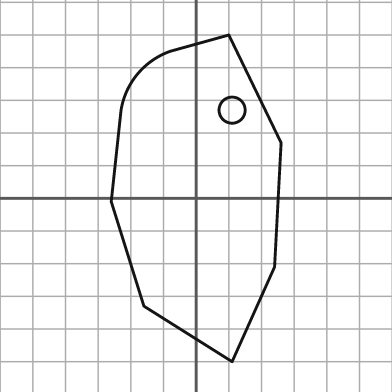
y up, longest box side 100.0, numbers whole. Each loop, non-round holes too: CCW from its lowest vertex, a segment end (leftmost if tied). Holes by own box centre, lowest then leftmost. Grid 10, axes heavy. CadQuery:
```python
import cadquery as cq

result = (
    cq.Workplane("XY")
    .moveTo(11.0, -50.0)
    .lineTo(24.0, -21.0)
    .lineTo(26.0, 17.0)
    .lineTo(10.0, 50.0)
    .lineTo(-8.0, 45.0)
    .threePointArc((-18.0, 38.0), (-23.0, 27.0))
    .lineTo(-26.0, -1.0)
    .lineTo(-16.0, -33.0)
    .close()
    .moveTo(11.0, 27.0)
    .circle(4.0)
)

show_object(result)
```